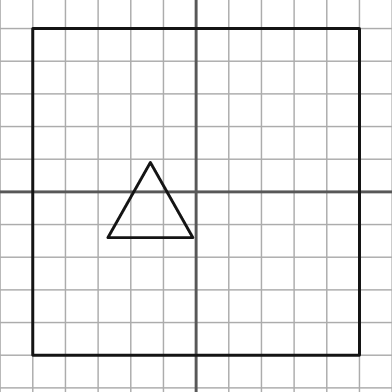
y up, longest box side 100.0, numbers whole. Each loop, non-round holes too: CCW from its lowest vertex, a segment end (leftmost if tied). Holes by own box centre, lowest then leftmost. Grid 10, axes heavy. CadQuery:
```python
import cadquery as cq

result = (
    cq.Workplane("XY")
    .moveTo(-50.0, -50.0)
    .lineTo(50.0, -50.0)
    .lineTo(50.0, 50.0)
    .lineTo(-50.0, 50.0)
    .close()
    .moveTo(-27.0, -14.0)
    .lineTo(-1.0, -14.0)
    .lineTo(-14.0, 9.0)
    .close()
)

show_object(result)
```